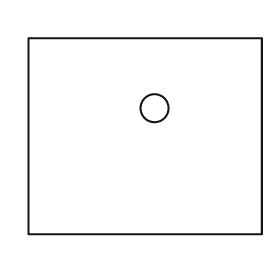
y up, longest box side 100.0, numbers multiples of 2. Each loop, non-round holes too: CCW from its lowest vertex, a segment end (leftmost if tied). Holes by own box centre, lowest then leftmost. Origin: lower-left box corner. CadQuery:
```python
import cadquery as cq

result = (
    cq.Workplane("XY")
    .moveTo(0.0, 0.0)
    .lineTo(100.0, 0.0)
    .lineTo(100.0, 84.0)
    .lineTo(0.0, 84.0)
    .close()
    .moveTo(54.0, 54.0)
    .circle(6.0)
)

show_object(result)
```